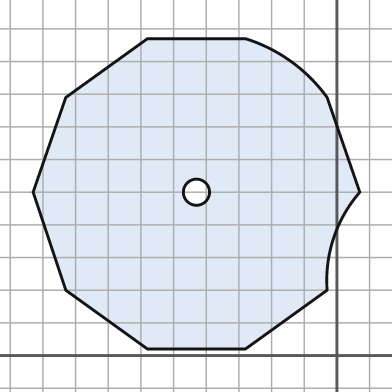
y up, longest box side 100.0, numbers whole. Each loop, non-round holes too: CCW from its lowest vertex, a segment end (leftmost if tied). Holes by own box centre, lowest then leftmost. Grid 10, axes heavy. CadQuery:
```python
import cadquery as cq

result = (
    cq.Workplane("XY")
    .moveTo(-58.0, 2.0)
    .lineTo(-28.0, 2.0)
    .lineTo(-3.0, 20.0)
    .threePointArc((-1.0, 36.0), (7.0, 50.0))
    .lineTo(-3.0, 79.0)
    .threePointArc((-14.0, 90.0), (-28.0, 97.0))
    .lineTo(-58.0, 97.0)
    .lineTo(-83.0, 79.0)
    .lineTo(-93.0, 50.0)
    .lineTo(-83.0, 20.0)
    .close()
    .moveTo(-43.0, 50.0)
    .circle(4.0)
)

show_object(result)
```